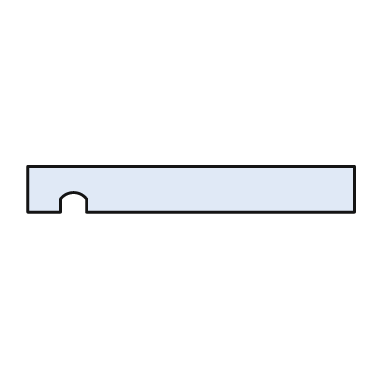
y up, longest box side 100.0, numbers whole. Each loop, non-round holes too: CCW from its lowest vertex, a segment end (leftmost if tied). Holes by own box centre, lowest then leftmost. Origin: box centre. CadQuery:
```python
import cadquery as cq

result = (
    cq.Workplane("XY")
    .moveTo(-50.0, -7.0)
    .lineTo(-40.0, -7.0)
    .lineTo(-40.0, -3.0)
    .threePointArc((-36.0, -1.0), (-32.0, -3.0))
    .lineTo(-32.0, -7.0)
    .lineTo(50.0, -7.0)
    .lineTo(50.0, 7.0)
    .lineTo(-50.0, 7.0)
    .close()
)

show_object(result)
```